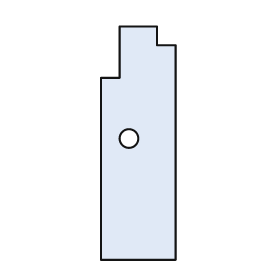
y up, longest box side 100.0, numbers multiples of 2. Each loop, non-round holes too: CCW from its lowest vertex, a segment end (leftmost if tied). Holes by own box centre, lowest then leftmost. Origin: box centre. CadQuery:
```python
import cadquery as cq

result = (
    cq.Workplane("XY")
    .moveTo(-16.0, -50.0)
    .lineTo(16.0, -50.0)
    .lineTo(16.0, 42.0)
    .lineTo(8.0, 42.0)
    .lineTo(8.0, 50.0)
    .lineTo(-8.0, 50.0)
    .lineTo(-8.0, 28.0)
    .lineTo(-16.0, 28.0)
    .close()
    .moveTo(-4.0, 2.0)
    .circle(4.0)
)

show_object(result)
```